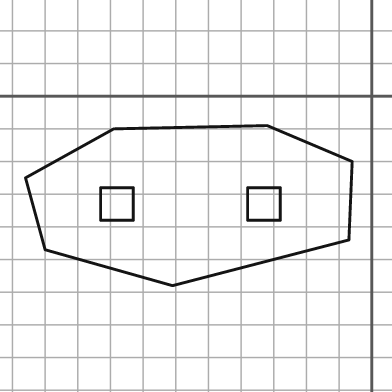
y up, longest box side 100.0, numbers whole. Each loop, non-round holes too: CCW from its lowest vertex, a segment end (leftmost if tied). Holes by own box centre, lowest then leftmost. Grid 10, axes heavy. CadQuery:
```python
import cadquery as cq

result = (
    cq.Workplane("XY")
    .moveTo(-61.0, -58.0)
    .lineTo(-7.0, -44.0)
    .lineTo(-6.0, -20.0)
    .lineTo(-32.0, -9.0)
    .lineTo(-79.0, -10.0)
    .lineTo(-106.0, -25.0)
    .lineTo(-100.0, -47.0)
    .close()
    .moveTo(-83.0, -38.0)
    .lineTo(-73.0, -38.0)
    .lineTo(-73.0, -28.0)
    .lineTo(-83.0, -28.0)
    .close()
    .moveTo(-38.0, -38.0)
    .lineTo(-28.0, -38.0)
    .lineTo(-28.0, -28.0)
    .lineTo(-38.0, -28.0)
    .close()
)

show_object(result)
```